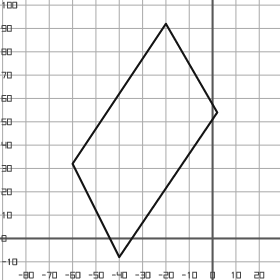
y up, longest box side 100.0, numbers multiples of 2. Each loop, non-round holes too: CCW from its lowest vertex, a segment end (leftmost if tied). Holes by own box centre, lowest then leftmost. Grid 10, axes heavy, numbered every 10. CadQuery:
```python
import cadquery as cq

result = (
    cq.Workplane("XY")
    .moveTo(-40.0, -8.0)
    .lineTo(2.0, 54.0)
    .lineTo(-20.0, 92.0)
    .lineTo(-60.0, 32.0)
    .close()
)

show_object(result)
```